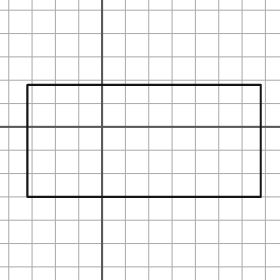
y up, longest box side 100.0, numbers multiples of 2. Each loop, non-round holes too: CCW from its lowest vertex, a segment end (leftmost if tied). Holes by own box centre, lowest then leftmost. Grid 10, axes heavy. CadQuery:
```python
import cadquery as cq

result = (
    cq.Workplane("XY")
    .moveTo(-32.0, -30.0)
    .lineTo(68.0, -30.0)
    .lineTo(68.0, 18.0)
    .lineTo(-32.0, 18.0)
    .close()
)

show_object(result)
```